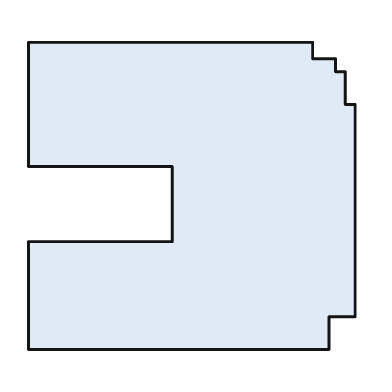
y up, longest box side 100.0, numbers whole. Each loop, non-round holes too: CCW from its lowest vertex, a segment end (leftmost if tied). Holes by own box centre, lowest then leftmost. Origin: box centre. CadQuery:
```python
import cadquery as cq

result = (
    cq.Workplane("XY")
    .moveTo(-50.0, -47.0)
    .lineTo(42.0, -47.0)
    .lineTo(42.0, -37.0)
    .lineTo(50.0, -37.0)
    .lineTo(50.0, 28.0)
    .lineTo(47.0, 28.0)
    .lineTo(47.0, 38.0)
    .lineTo(44.0, 38.0)
    .lineTo(44.0, 42.0)
    .lineTo(37.0, 42.0)
    .lineTo(37.0, 47.0)
    .lineTo(-50.0, 47.0)
    .lineTo(-50.0, 9.0)
    .lineTo(-6.0, 9.0)
    .lineTo(-6.0, -14.0)
    .lineTo(-50.0, -14.0)
    .close()
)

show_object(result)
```